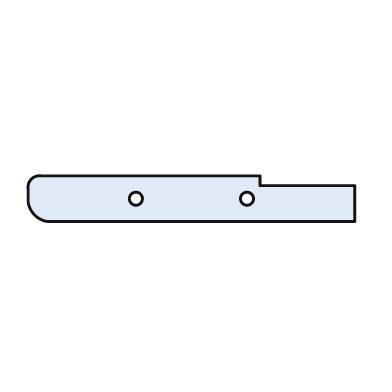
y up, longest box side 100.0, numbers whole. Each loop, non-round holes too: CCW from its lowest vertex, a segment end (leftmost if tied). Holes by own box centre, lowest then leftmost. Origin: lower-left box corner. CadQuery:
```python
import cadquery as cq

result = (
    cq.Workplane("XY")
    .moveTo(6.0, 0.0)
    .lineTo(100.0, 0.0)
    .lineTo(100.0, 11.0)
    .lineTo(71.0, 11.0)
    .lineTo(71.0, 14.0)
    .lineTo(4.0, 14.0)
    .threePointArc((1.0, 13.0), (0.0, 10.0))
    .lineTo(0.0, 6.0)
    .threePointArc((2.0, 2.0), (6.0, 0.0))
    .close()
    .moveTo(33.0, 7.0)
    .circle(2.0)
    .moveTo(67.0, 7.0)
    .circle(2.0)
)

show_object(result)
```